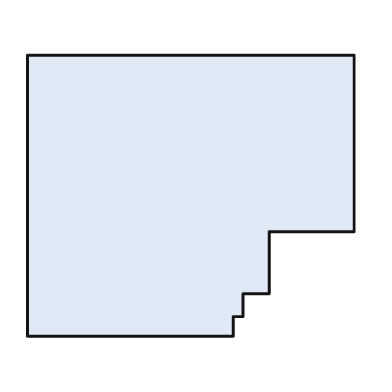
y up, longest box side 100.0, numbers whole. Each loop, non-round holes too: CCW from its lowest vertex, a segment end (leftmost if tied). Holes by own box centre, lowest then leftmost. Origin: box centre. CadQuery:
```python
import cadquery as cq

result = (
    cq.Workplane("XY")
    .moveTo(-50.0, -43.0)
    .lineTo(13.0, -43.0)
    .lineTo(13.0, -37.0)
    .lineTo(16.0, -37.0)
    .lineTo(16.0, -30.0)
    .lineTo(24.0, -30.0)
    .lineTo(24.0, -11.0)
    .lineTo(50.0, -11.0)
    .lineTo(50.0, 43.0)
    .lineTo(-50.0, 43.0)
    .close()
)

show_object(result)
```